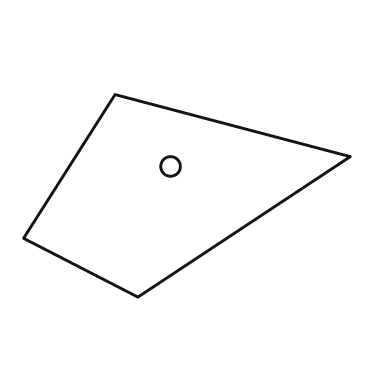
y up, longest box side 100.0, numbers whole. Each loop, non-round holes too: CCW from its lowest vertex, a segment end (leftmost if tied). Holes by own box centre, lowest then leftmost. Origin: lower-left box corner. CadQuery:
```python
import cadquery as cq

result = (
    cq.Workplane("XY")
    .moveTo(35.0, 0.0)
    .lineTo(100.0, 43.0)
    .lineTo(28.0, 62.0)
    .lineTo(0.0, 18.0)
    .close()
    .moveTo(45.0, 40.0)
    .circle(3.0)
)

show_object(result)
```